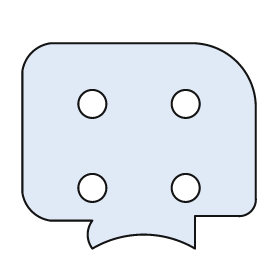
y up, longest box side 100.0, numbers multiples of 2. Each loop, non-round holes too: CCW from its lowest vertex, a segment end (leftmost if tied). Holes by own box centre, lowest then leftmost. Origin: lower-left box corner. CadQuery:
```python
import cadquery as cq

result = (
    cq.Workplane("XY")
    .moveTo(30.0, 0.0)
    .threePointArc((52.0, 6.0), (74.0, 0.0))
    .lineTo(74.0, 14.0)
    .lineTo(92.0, 14.0)
    .threePointArc((98.0, 16.0), (100.0, 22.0))
    .lineTo(100.0, 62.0)
    .threePointArc((92.0, 80.0), (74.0, 88.0))
    .lineTo(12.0, 88.0)
    .threePointArc((4.0, 84.0), (0.0, 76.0))
    .lineTo(0.0, 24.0)
    .threePointArc((4.0, 16.0), (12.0, 12.0))
    .lineTo(30.0, 12.0)
    .threePointArc((28.0, 6.0), (30.0, 0.0))
    .close()
    .moveTo(30.0, 26.0)
    .circle(6.0)
    .moveTo(70.0, 26.0)
    .circle(6.0)
    .moveTo(30.0, 62.0)
    .circle(6.0)
    .moveTo(70.0, 62.0)
    .circle(6.0)
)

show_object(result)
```